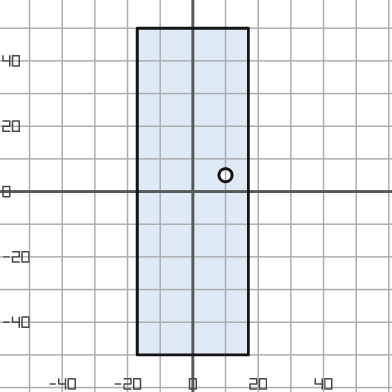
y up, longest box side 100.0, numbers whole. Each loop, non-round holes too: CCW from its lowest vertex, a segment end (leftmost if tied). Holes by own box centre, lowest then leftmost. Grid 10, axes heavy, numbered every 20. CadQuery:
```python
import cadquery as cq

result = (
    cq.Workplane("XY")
    .moveTo(-17.0, -50.0)
    .lineTo(17.0, -50.0)
    .lineTo(17.0, 50.0)
    .lineTo(-17.0, 50.0)
    .close()
    .moveTo(10.0, 5.0)
    .circle(2.0)
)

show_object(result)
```